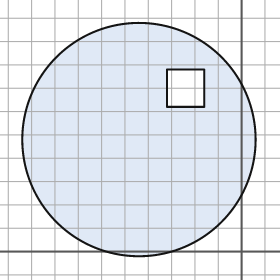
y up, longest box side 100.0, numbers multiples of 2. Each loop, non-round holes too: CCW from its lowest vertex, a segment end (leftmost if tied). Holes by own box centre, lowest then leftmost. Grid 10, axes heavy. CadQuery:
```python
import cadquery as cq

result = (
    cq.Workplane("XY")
    .moveTo(-44.0, 48.0)
    .circle(50.0)
    .moveTo(-32.0, 62.0)
    .lineTo(-16.0, 62.0)
    .lineTo(-16.0, 78.0)
    .lineTo(-32.0, 78.0)
    .close()
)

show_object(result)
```